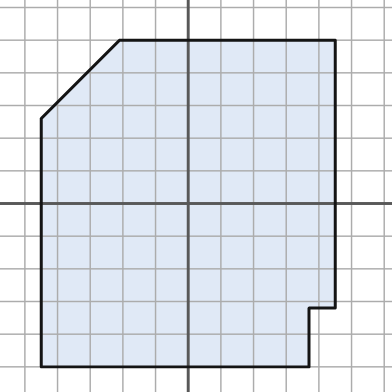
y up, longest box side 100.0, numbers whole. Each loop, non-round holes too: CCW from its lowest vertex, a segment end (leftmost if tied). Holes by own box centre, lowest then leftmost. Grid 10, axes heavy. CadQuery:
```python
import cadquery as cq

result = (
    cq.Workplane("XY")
    .moveTo(-45.0, -50.0)
    .lineTo(37.0, -50.0)
    .lineTo(37.0, -32.0)
    .lineTo(45.0, -32.0)
    .lineTo(45.0, 50.0)
    .lineTo(-21.0, 50.0)
    .lineTo(-45.0, 26.0)
    .close()
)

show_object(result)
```